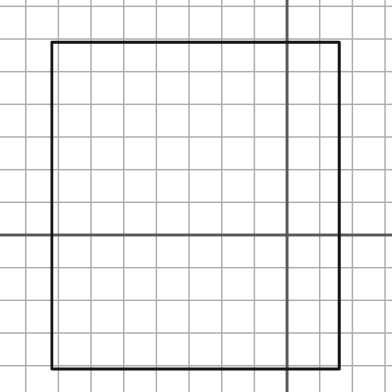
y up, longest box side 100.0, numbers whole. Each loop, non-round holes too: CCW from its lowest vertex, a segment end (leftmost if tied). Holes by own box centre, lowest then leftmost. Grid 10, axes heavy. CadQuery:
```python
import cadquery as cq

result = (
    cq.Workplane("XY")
    .moveTo(-72.0, -41.0)
    .lineTo(16.0, -41.0)
    .lineTo(16.0, 59.0)
    .lineTo(-72.0, 59.0)
    .close()
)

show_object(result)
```